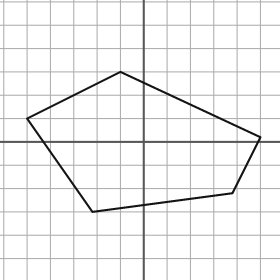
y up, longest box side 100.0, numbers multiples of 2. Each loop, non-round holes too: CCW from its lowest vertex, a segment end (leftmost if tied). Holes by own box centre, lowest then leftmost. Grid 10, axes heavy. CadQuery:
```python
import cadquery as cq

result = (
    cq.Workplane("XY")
    .moveTo(-22.0, -30.0)
    .lineTo(38.0, -22.0)
    .lineTo(50.0, 2.0)
    .lineTo(-10.0, 30.0)
    .lineTo(-50.0, 10.0)
    .close()
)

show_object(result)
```